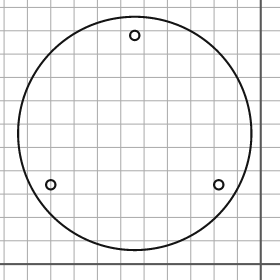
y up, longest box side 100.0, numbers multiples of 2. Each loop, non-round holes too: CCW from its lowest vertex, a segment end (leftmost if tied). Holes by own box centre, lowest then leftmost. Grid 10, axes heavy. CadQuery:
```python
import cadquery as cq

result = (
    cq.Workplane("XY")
    .moveTo(-54.0, 56.0)
    .circle(50.0)
    .moveTo(-90.0, 34.0)
    .circle(2.0)
    .moveTo(-18.0, 34.0)
    .circle(2.0)
    .moveTo(-54.0, 98.0)
    .circle(2.0)
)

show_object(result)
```